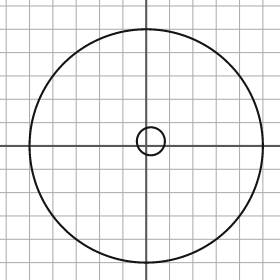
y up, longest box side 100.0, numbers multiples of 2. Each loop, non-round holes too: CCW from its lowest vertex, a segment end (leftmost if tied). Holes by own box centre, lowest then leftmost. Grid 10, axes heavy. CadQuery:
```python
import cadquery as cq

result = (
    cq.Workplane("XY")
    .moveTo(0.0, 0.0)
    .circle(50.0)
    .moveTo(2.0, 2.0)
    .circle(6.0)
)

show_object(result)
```